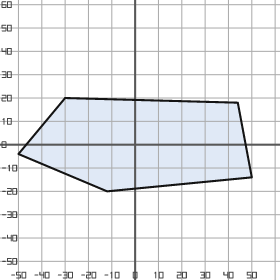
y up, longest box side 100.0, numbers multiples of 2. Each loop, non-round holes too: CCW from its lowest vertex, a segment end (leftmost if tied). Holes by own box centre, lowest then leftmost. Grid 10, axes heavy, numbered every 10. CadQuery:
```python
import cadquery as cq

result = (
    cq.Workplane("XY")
    .moveTo(-12.0, -20.0)
    .lineTo(50.0, -14.0)
    .lineTo(44.0, 18.0)
    .lineTo(-30.0, 20.0)
    .lineTo(-50.0, -4.0)
    .close()
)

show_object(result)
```